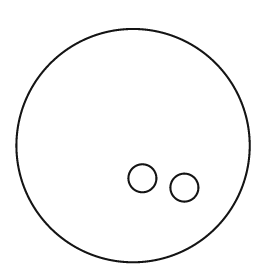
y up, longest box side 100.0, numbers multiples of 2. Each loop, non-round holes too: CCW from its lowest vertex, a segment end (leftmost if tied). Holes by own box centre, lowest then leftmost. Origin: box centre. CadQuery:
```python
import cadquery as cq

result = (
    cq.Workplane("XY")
    .moveTo(0.0, 0.0)
    .circle(50.0)
    .moveTo(22.0, -18.0)
    .circle(6.0)
    .moveTo(4.0, -14.0)
    .circle(6.0)
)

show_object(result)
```